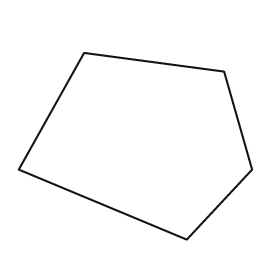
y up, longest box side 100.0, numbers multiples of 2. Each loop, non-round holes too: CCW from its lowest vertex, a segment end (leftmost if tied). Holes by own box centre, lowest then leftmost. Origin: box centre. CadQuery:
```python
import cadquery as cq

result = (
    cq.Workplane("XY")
    .moveTo(22.0, -40.0)
    .lineTo(50.0, -10.0)
    .lineTo(38.0, 32.0)
    .lineTo(-22.0, 40.0)
    .lineTo(-50.0, -10.0)
    .close()
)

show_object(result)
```